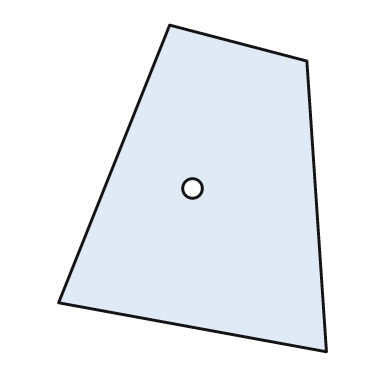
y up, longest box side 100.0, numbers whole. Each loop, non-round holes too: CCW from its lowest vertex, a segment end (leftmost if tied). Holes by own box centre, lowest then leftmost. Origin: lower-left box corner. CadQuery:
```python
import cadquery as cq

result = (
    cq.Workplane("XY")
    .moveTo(82.0, 0.0)
    .lineTo(76.0, 89.0)
    .lineTo(34.0, 100.0)
    .lineTo(0.0, 15.0)
    .close()
    .moveTo(41.0, 50.0)
    .circle(3.0)
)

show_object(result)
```